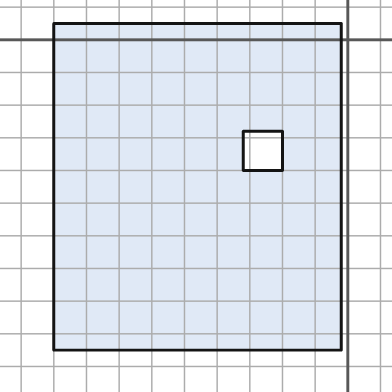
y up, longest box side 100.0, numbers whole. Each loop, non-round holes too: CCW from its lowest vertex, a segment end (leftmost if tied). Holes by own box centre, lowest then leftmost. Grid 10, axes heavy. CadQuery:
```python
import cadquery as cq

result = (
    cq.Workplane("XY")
    .moveTo(-90.0, -95.0)
    .lineTo(-2.0, -95.0)
    .lineTo(-2.0, 5.0)
    .lineTo(-90.0, 5.0)
    .close()
    .moveTo(-32.0, -40.0)
    .lineTo(-20.0, -40.0)
    .lineTo(-20.0, -28.0)
    .lineTo(-32.0, -28.0)
    .close()
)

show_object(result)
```